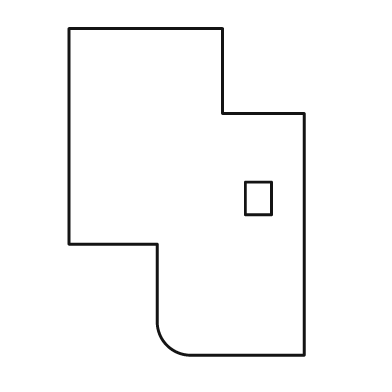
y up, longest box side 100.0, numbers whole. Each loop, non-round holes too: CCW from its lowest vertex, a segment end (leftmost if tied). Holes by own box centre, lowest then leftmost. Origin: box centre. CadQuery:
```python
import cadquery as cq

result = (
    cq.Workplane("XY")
    .moveTo(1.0, -50.0)
    .lineTo(36.0, -50.0)
    .lineTo(36.0, 24.0)
    .lineTo(11.0, 24.0)
    .lineTo(11.0, 50.0)
    .lineTo(-36.0, 50.0)
    .lineTo(-36.0, -16.0)
    .lineTo(-9.0, -16.0)
    .lineTo(-9.0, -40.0)
    .threePointArc((-6.0, -47.0), (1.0, -50.0))
    .close()
    .moveTo(18.0, -7.0)
    .lineTo(26.0, -7.0)
    .lineTo(26.0, 3.0)
    .lineTo(18.0, 3.0)
    .close()
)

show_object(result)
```